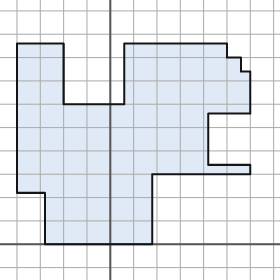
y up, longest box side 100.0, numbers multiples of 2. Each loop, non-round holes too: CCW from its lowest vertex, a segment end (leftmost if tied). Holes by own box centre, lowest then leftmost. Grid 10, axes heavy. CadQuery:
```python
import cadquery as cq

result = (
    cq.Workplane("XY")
    .moveTo(-28.0, 0.0)
    .lineTo(18.0, 0.0)
    .lineTo(18.0, 30.0)
    .lineTo(60.0, 30.0)
    .lineTo(60.0, 34.0)
    .lineTo(42.0, 34.0)
    .lineTo(42.0, 56.0)
    .lineTo(60.0, 56.0)
    .lineTo(60.0, 74.0)
    .lineTo(56.0, 74.0)
    .lineTo(56.0, 80.0)
    .lineTo(50.0, 80.0)
    .lineTo(50.0, 86.0)
    .lineTo(6.0, 86.0)
    .lineTo(6.0, 60.0)
    .lineTo(-20.0, 60.0)
    .lineTo(-20.0, 86.0)
    .lineTo(-40.0, 86.0)
    .lineTo(-40.0, 22.0)
    .lineTo(-28.0, 22.0)
    .close()
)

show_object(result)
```